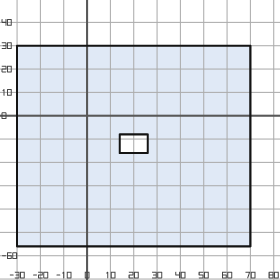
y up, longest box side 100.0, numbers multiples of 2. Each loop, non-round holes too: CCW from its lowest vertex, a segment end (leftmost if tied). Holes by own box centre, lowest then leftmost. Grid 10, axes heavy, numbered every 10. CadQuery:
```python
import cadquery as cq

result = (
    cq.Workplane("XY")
    .moveTo(-30.0, -56.0)
    .lineTo(70.0, -56.0)
    .lineTo(70.0, 30.0)
    .lineTo(-30.0, 30.0)
    .close()
    .moveTo(14.0, -16.0)
    .lineTo(26.0, -16.0)
    .lineTo(26.0, -8.0)
    .lineTo(14.0, -8.0)
    .close()
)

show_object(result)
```